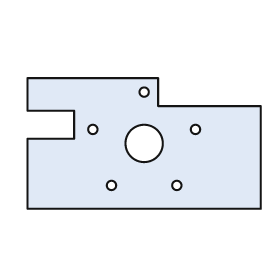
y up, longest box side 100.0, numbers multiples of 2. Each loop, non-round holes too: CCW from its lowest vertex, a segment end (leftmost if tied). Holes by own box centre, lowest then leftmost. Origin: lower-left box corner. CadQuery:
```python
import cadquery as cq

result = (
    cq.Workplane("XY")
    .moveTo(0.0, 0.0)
    .lineTo(100.0, 0.0)
    .lineTo(100.0, 44.0)
    .lineTo(56.0, 44.0)
    .lineTo(56.0, 56.0)
    .lineTo(0.0, 56.0)
    .lineTo(0.0, 42.0)
    .lineTo(20.0, 42.0)
    .lineTo(20.0, 30.0)
    .lineTo(0.0, 30.0)
    .close()
    .moveTo(36.0, 10.0)
    .circle(2.0)
    .moveTo(64.0, 10.0)
    .circle(2.0)
    .moveTo(50.0, 28.0)
    .circle(8.0)
    .moveTo(28.0, 34.0)
    .circle(2.0)
    .moveTo(72.0, 34.0)
    .circle(2.0)
    .moveTo(50.0, 50.0)
    .circle(2.0)
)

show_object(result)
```